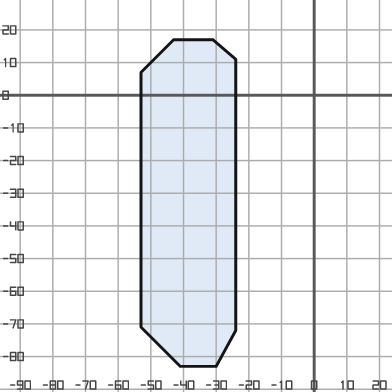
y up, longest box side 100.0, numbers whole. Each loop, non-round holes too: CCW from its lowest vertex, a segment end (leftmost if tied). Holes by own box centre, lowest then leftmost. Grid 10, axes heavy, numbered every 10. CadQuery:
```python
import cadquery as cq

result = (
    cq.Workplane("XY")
    .moveTo(-41.0, -83.0)
    .lineTo(-30.0, -83.0)
    .lineTo(-24.0, -72.0)
    .lineTo(-24.0, 11.0)
    .lineTo(-31.0, 17.0)
    .lineTo(-43.0, 17.0)
    .lineTo(-53.0, 7.0)
    .lineTo(-53.0, -71.0)
    .close()
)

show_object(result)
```